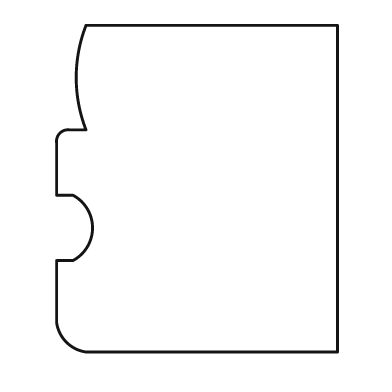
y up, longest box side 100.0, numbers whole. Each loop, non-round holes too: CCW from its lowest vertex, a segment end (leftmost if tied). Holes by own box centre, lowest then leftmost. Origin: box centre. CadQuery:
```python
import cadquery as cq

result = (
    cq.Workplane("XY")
    .moveTo(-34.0, -50.0)
    .lineTo(43.0, -50.0)
    .lineTo(43.0, 50.0)
    .lineTo(-34.0, 50.0)
    .threePointArc((-37.0, 34.0), (-34.0, 18.0))
    .lineTo(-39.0, 18.0)
    .threePointArc((-42.0, 17.0), (-43.0, 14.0))
    .lineTo(-43.0, -2.0)
    .lineTo(-38.0, -2.0)
    .threePointArc((-32.0, -12.0), (-38.0, -22.0))
    .lineTo(-43.0, -22.0)
    .lineTo(-43.0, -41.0)
    .threePointArc((-40.0, -47.0), (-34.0, -50.0))
    .close()
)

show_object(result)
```